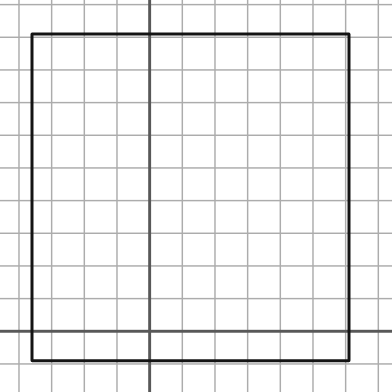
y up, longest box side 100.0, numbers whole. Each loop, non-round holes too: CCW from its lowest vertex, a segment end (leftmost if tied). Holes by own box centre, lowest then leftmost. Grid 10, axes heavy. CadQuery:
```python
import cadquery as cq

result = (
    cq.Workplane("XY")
    .moveTo(-36.0, -9.0)
    .lineTo(61.0, -9.0)
    .lineTo(61.0, 91.0)
    .lineTo(-36.0, 91.0)
    .close()
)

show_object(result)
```